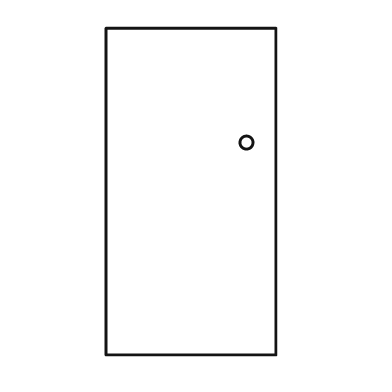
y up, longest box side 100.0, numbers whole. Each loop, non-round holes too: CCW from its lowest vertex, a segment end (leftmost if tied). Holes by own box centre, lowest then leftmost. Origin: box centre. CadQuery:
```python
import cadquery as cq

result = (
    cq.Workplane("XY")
    .moveTo(-26.0, -50.0)
    .lineTo(26.0, -50.0)
    .lineTo(26.0, 50.0)
    .lineTo(-26.0, 50.0)
    .close()
    .moveTo(17.0, 15.0)
    .circle(2.0)
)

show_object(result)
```